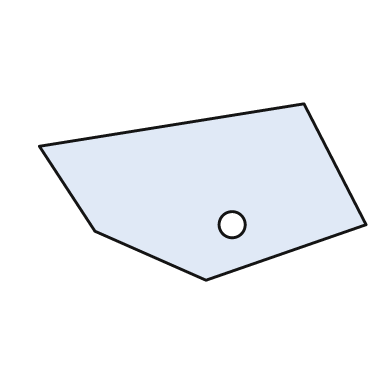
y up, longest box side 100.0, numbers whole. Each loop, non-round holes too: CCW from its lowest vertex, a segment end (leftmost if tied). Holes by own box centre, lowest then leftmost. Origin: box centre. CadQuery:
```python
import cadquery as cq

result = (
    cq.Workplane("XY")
    .moveTo(1.0, -27.0)
    .lineTo(50.0, -10.0)
    .lineTo(31.0, 27.0)
    .lineTo(-50.0, 14.0)
    .lineTo(-33.0, -12.0)
    .close()
    .moveTo(9.0, -10.0)
    .circle(4.0)
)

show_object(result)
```